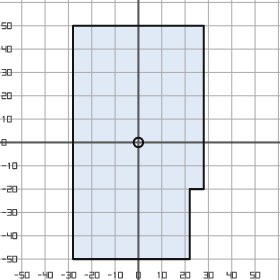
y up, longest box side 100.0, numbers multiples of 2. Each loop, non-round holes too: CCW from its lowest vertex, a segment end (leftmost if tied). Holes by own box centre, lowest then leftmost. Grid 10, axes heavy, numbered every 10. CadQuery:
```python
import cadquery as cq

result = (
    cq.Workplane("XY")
    .moveTo(-28.0, -50.0)
    .lineTo(22.0, -50.0)
    .lineTo(22.0, -20.0)
    .lineTo(28.0, -20.0)
    .lineTo(28.0, 50.0)
    .lineTo(-28.0, 50.0)
    .close()
    .moveTo(0.0, 0.0)
    .circle(2.0)
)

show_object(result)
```